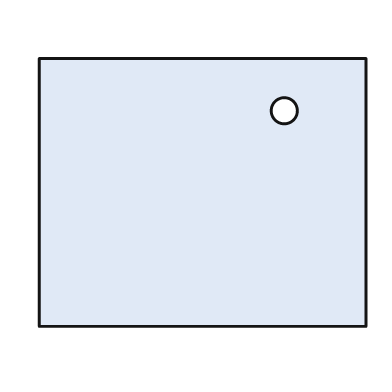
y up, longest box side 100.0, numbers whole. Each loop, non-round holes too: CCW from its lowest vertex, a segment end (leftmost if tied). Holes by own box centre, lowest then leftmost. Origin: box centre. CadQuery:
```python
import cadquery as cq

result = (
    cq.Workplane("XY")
    .moveTo(-50.0, -41.0)
    .lineTo(50.0, -41.0)
    .lineTo(50.0, 41.0)
    .lineTo(-50.0, 41.0)
    .close()
    .moveTo(25.0, 25.0)
    .circle(4.0)
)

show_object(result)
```